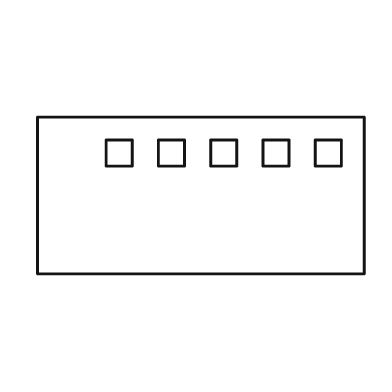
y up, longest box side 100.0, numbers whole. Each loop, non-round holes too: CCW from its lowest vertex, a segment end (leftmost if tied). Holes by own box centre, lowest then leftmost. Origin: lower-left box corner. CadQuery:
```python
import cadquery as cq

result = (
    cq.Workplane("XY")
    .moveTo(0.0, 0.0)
    .lineTo(100.0, 0.0)
    .lineTo(100.0, 48.0)
    .lineTo(0.0, 48.0)
    .close()
    .moveTo(21.0, 33.0)
    .lineTo(29.0, 33.0)
    .lineTo(29.0, 41.0)
    .lineTo(21.0, 41.0)
    .close()
    .moveTo(37.0, 33.0)
    .lineTo(45.0, 33.0)
    .lineTo(45.0, 41.0)
    .lineTo(37.0, 41.0)
    .close()
    .moveTo(53.0, 33.0)
    .lineTo(61.0, 33.0)
    .lineTo(61.0, 41.0)
    .lineTo(53.0, 41.0)
    .close()
    .moveTo(69.0, 33.0)
    .lineTo(77.0, 33.0)
    .lineTo(77.0, 41.0)
    .lineTo(69.0, 41.0)
    .close()
    .moveTo(85.0, 33.0)
    .lineTo(93.0, 33.0)
    .lineTo(93.0, 41.0)
    .lineTo(85.0, 41.0)
    .close()
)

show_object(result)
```